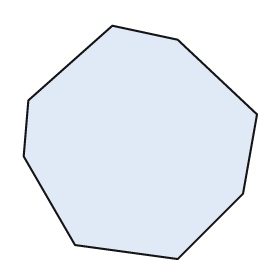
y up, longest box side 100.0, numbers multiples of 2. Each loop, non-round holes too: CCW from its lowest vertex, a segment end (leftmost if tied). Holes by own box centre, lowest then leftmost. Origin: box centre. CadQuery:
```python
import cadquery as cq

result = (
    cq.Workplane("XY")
    .moveTo(16.0, -50.0)
    .lineTo(44.0, -22.0)
    .lineTo(50.0, 12.0)
    .lineTo(16.0, 44.0)
    .lineTo(-12.0, 50.0)
    .lineTo(-48.0, 18.0)
    .lineTo(-50.0, -6.0)
    .lineTo(-28.0, -44.0)
    .close()
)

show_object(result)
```